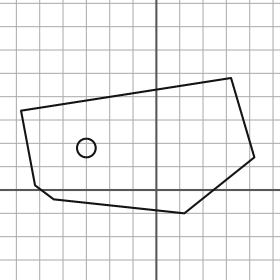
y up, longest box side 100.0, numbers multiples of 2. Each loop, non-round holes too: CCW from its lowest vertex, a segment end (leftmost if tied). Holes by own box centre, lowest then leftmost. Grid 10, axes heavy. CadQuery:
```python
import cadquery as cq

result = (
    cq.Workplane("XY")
    .moveTo(12.0, -10.0)
    .lineTo(42.0, 14.0)
    .lineTo(32.0, 48.0)
    .lineTo(-58.0, 34.0)
    .lineTo(-52.0, 2.0)
    .lineTo(-44.0, -4.0)
    .close()
    .moveTo(-30.0, 18.0)
    .circle(4.0)
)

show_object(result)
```